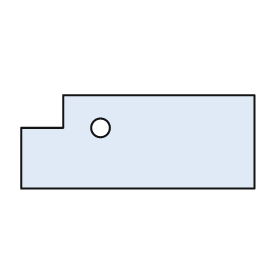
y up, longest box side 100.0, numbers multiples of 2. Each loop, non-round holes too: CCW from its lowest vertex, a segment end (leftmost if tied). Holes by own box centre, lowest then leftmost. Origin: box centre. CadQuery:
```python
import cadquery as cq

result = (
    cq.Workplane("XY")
    .moveTo(-50.0, -20.0)
    .lineTo(50.0, -20.0)
    .lineTo(50.0, 20.0)
    .lineTo(-32.0, 20.0)
    .lineTo(-32.0, 6.0)
    .lineTo(-50.0, 6.0)
    .close()
    .moveTo(-16.0, 6.0)
    .circle(4.0)
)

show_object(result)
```